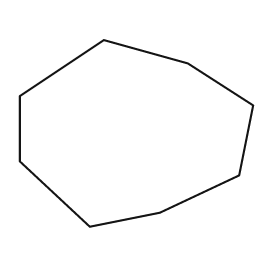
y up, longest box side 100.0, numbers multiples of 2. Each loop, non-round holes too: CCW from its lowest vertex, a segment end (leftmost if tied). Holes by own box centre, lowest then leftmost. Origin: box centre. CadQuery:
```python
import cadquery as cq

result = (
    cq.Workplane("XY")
    .moveTo(-20.0, -40.0)
    .lineTo(10.0, -34.0)
    .lineTo(44.0, -18.0)
    .lineTo(50.0, 12.0)
    .lineTo(22.0, 30.0)
    .lineTo(-14.0, 40.0)
    .lineTo(-50.0, 16.0)
    .lineTo(-50.0, -12.0)
    .close()
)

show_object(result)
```